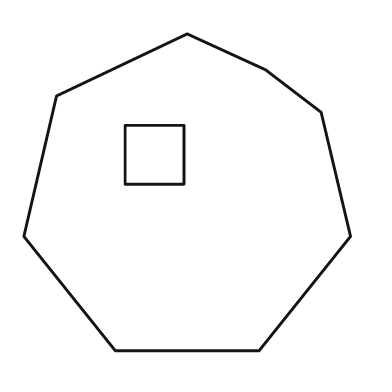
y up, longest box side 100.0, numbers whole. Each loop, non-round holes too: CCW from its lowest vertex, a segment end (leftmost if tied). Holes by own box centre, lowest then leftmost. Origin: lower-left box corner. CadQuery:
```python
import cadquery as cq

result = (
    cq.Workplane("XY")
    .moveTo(28.0, 0.0)
    .lineTo(72.0, 0.0)
    .lineTo(100.0, 35.0)
    .lineTo(91.0, 73.0)
    .lineTo(74.0, 86.0)
    .lineTo(50.0, 97.0)
    .lineTo(10.0, 78.0)
    .lineTo(0.0, 35.0)
    .close()
    .moveTo(31.0, 51.0)
    .lineTo(49.0, 51.0)
    .lineTo(49.0, 69.0)
    .lineTo(31.0, 69.0)
    .close()
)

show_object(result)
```